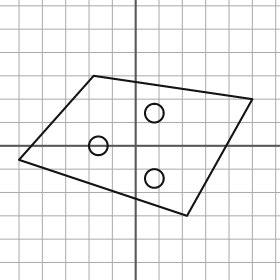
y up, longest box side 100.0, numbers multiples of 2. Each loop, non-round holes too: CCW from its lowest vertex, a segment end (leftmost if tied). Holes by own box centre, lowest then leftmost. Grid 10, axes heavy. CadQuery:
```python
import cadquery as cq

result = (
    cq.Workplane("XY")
    .moveTo(22.0, -30.0)
    .lineTo(50.0, 20.0)
    .lineTo(-18.0, 30.0)
    .lineTo(-50.0, -6.0)
    .close()
    .moveTo(8.0, -14.0)
    .circle(4.0)
    .moveTo(-16.0, 0.0)
    .circle(4.0)
    .moveTo(8.0, 14.0)
    .circle(4.0)
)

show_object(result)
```